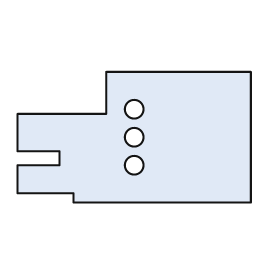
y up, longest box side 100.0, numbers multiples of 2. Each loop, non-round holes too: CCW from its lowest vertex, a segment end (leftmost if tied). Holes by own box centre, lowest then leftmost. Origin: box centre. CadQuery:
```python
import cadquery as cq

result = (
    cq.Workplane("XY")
    .moveTo(-26.0, -28.0)
    .lineTo(50.0, -28.0)
    .lineTo(50.0, 28.0)
    .lineTo(-12.0, 28.0)
    .lineTo(-12.0, 10.0)
    .lineTo(-50.0, 10.0)
    .lineTo(-50.0, -6.0)
    .lineTo(-32.0, -6.0)
    .lineTo(-32.0, -12.0)
    .lineTo(-50.0, -12.0)
    .lineTo(-50.0, -24.0)
    .lineTo(-26.0, -24.0)
    .close()
    .moveTo(0.0, -12.0)
    .circle(4.0)
    .moveTo(0.0, 0.0)
    .circle(4.0)
    .moveTo(0.0, 12.0)
    .circle(4.0)
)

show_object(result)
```